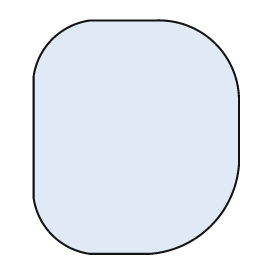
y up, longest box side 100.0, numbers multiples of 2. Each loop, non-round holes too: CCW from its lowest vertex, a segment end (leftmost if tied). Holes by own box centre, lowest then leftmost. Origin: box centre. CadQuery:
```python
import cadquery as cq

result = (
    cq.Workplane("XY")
    .moveTo(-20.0, -50.0)
    .lineTo(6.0, -50.0)
    .threePointArc((32.0, -38.0), (44.0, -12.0))
    .lineTo(44.0, 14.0)
    .threePointArc((34.0, 40.0), (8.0, 50.0))
    .lineTo(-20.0, 50.0)
    .threePointArc((-36.0, 42.0), (-44.0, 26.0))
    .lineTo(-44.0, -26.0)
    .threePointArc((-36.0, -42.0), (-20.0, -50.0))
    .close()
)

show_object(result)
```